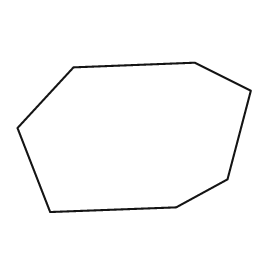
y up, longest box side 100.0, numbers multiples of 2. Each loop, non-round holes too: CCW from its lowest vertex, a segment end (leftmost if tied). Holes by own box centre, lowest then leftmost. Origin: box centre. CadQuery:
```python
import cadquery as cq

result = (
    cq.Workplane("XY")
    .moveTo(-36.0, -32.0)
    .lineTo(18.0, -30.0)
    .lineTo(40.0, -18.0)
    .lineTo(50.0, 20.0)
    .lineTo(26.0, 32.0)
    .lineTo(-26.0, 30.0)
    .lineTo(-50.0, 4.0)
    .close()
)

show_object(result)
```